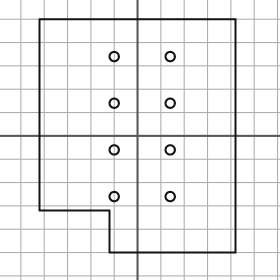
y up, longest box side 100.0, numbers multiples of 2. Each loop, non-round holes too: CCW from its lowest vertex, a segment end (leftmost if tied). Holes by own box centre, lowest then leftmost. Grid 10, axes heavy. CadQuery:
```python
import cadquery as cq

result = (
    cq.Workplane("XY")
    .moveTo(-12.0, -50.0)
    .lineTo(42.0, -50.0)
    .lineTo(42.0, 50.0)
    .lineTo(-42.0, 50.0)
    .lineTo(-42.0, -32.0)
    .lineTo(-12.0, -32.0)
    .close()
    .moveTo(-10.0, -26.0)
    .circle(2.0)
    .moveTo(14.0, -26.0)
    .circle(2.0)
    .moveTo(-10.0, -6.0)
    .circle(2.0)
    .moveTo(14.0, -6.0)
    .circle(2.0)
    .moveTo(-10.0, 14.0)
    .circle(2.0)
    .moveTo(14.0, 14.0)
    .circle(2.0)
    .moveTo(-10.0, 34.0)
    .circle(2.0)
    .moveTo(14.0, 34.0)
    .circle(2.0)
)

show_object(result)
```